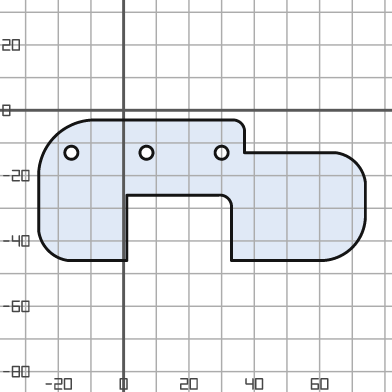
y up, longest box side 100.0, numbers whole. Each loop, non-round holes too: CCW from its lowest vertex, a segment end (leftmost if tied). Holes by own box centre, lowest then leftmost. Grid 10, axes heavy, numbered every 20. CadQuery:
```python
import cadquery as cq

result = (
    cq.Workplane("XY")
    .moveTo(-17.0, -46.0)
    .lineTo(1.0, -46.0)
    .lineTo(1.0, -26.0)
    .lineTo(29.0, -26.0)
    .threePointArc((32.0, -27.0), (33.0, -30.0))
    .lineTo(33.0, -46.0)
    .lineTo(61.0, -46.0)
    .threePointArc((70.0, -42.0), (74.0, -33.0))
    .lineTo(74.0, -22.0)
    .threePointArc((71.0, -16.0), (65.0, -13.0))
    .lineTo(37.0, -13.0)
    .lineTo(37.0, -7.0)
    .threePointArc((36.0, -4.0), (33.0, -3.0))
    .lineTo(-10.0, -3.0)
    .threePointArc((-21.0, -8.0), (-26.0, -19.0))
    .lineTo(-26.0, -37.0)
    .threePointArc((-23.0, -43.0), (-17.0, -46.0))
    .close()
    .moveTo(-16.0, -13.0)
    .circle(2.0)
    .moveTo(7.0, -13.0)
    .circle(2.0)
    .moveTo(30.0, -13.0)
    .circle(2.0)
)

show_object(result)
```